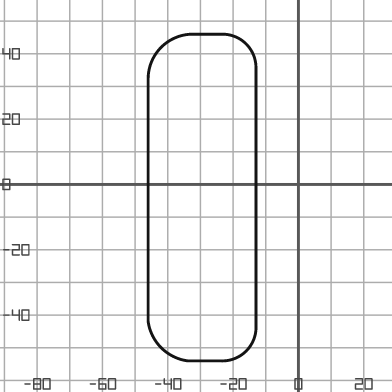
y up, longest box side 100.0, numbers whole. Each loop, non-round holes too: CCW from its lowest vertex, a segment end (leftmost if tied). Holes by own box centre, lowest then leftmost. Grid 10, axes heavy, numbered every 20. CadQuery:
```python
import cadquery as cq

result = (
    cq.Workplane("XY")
    .moveTo(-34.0, -54.0)
    .lineTo(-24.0, -54.0)
    .threePointArc((-16.0, -51.0), (-13.0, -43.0))
    .lineTo(-13.0, 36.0)
    .threePointArc((-16.0, 43.0), (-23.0, 46.0))
    .lineTo(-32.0, 46.0)
    .threePointArc((-42.0, 42.0), (-46.0, 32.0))
    .lineTo(-46.0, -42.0)
    .threePointArc((-42.0, -50.0), (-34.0, -54.0))
    .close()
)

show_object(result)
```